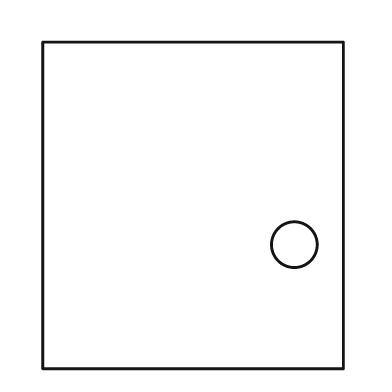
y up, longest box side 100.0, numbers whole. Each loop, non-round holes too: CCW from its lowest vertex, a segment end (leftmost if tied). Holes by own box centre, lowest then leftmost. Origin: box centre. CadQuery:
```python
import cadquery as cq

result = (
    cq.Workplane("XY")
    .moveTo(-46.0, -50.0)
    .lineTo(46.0, -50.0)
    .lineTo(46.0, 50.0)
    .lineTo(-46.0, 50.0)
    .close()
    .moveTo(31.0, -12.0)
    .circle(7.0)
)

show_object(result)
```